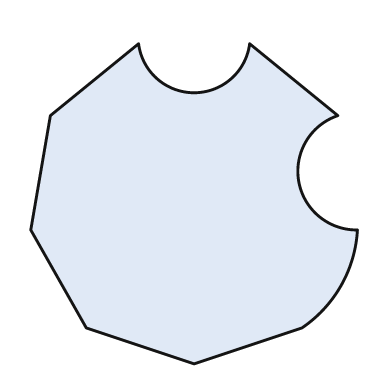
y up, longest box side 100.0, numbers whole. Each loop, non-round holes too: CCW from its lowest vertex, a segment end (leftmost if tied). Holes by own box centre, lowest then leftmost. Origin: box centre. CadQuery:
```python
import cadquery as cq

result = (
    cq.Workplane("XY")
    .moveTo(0.0, -49.0)
    .lineTo(33.0, -38.0)
    .threePointArc((45.0, -25.0), (50.0, -8.0))
    .threePointArc((32.0, 7.0), (44.0, 27.0))
    .lineTo(17.0, 49.0)
    .threePointArc((0.0, 34.0), (-17.0, 49.0))
    .lineTo(-44.0, 27.0)
    .lineTo(-50.0, -8.0)
    .lineTo(-33.0, -38.0)
    .close()
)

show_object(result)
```